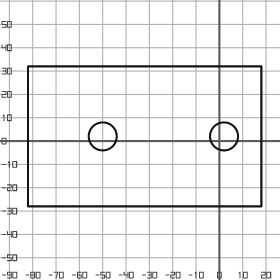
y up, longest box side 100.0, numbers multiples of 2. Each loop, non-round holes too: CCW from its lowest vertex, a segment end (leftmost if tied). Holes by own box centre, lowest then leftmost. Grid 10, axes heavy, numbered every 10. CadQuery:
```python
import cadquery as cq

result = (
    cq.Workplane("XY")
    .moveTo(-82.0, -28.0)
    .lineTo(18.0, -28.0)
    .lineTo(18.0, 32.0)
    .lineTo(-82.0, 32.0)
    .close()
    .moveTo(-50.0, 2.0)
    .circle(6.0)
    .moveTo(2.0, 2.0)
    .circle(6.0)
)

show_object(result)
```